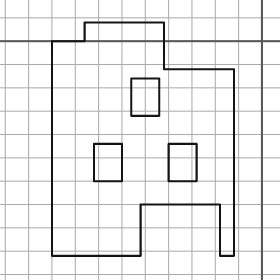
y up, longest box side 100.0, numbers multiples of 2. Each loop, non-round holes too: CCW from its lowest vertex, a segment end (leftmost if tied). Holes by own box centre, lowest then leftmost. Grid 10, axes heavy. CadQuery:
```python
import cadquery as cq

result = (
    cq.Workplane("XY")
    .moveTo(-90.0, -92.0)
    .lineTo(-52.0, -92.0)
    .lineTo(-52.0, -70.0)
    .lineTo(-18.0, -70.0)
    .lineTo(-18.0, -92.0)
    .lineTo(-12.0, -92.0)
    .lineTo(-12.0, -12.0)
    .lineTo(-42.0, -12.0)
    .lineTo(-42.0, 8.0)
    .lineTo(-76.0, 8.0)
    .lineTo(-76.0, 0.0)
    .lineTo(-90.0, 0.0)
    .close()
    .moveTo(-72.0, -60.0)
    .lineTo(-60.0, -60.0)
    .lineTo(-60.0, -44.0)
    .lineTo(-72.0, -44.0)
    .close()
    .moveTo(-40.0, -60.0)
    .lineTo(-28.0, -60.0)
    .lineTo(-28.0, -44.0)
    .lineTo(-40.0, -44.0)
    .close()
    .moveTo(-56.0, -32.0)
    .lineTo(-44.0, -32.0)
    .lineTo(-44.0, -16.0)
    .lineTo(-56.0, -16.0)
    .close()
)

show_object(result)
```